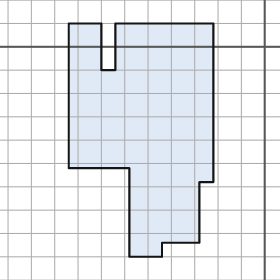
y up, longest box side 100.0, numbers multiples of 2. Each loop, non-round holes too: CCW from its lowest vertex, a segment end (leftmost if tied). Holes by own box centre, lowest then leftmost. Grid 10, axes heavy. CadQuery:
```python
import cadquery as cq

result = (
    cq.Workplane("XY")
    .moveTo(-58.0, -90.0)
    .lineTo(-44.0, -90.0)
    .lineTo(-44.0, -84.0)
    .lineTo(-28.0, -84.0)
    .lineTo(-28.0, -58.0)
    .lineTo(-22.0, -58.0)
    .lineTo(-22.0, 10.0)
    .lineTo(-64.0, 10.0)
    .lineTo(-64.0, -10.0)
    .lineTo(-70.0, -10.0)
    .lineTo(-70.0, 10.0)
    .lineTo(-84.0, 10.0)
    .lineTo(-84.0, -52.0)
    .lineTo(-58.0, -52.0)
    .close()
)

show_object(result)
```